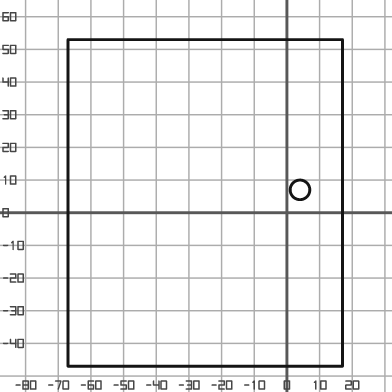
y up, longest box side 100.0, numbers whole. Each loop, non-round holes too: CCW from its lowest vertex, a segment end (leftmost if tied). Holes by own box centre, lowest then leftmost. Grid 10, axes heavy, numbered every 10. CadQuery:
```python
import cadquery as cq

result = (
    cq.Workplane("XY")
    .moveTo(-67.0, -47.0)
    .lineTo(17.0, -47.0)
    .lineTo(17.0, 53.0)
    .lineTo(-67.0, 53.0)
    .close()
    .moveTo(4.0, 7.0)
    .circle(3.0)
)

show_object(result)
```